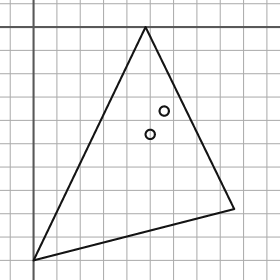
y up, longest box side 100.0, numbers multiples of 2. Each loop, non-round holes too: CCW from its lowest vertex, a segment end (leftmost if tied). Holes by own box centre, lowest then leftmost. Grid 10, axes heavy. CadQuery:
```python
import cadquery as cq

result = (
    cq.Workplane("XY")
    .moveTo(0.0, -100.0)
    .lineTo(86.0, -78.0)
    .lineTo(48.0, 0.0)
    .close()
    .moveTo(50.0, -46.0)
    .circle(2.0)
    .moveTo(56.0, -36.0)
    .circle(2.0)
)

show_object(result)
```